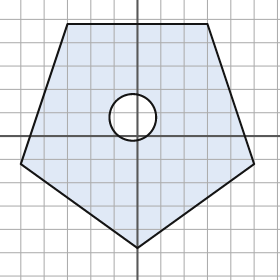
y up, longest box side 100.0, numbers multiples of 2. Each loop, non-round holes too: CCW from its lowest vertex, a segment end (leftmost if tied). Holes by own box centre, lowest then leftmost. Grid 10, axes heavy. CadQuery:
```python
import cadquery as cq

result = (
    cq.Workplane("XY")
    .moveTo(0.0, -48.0)
    .lineTo(50.0, -12.0)
    .lineTo(30.0, 48.0)
    .lineTo(-30.0, 48.0)
    .lineTo(-50.0, -12.0)
    .close()
    .moveTo(-2.0, 8.0)
    .circle(10.0)
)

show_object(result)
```